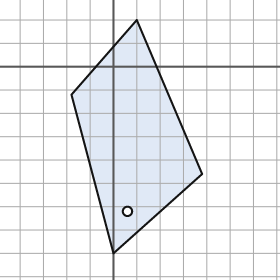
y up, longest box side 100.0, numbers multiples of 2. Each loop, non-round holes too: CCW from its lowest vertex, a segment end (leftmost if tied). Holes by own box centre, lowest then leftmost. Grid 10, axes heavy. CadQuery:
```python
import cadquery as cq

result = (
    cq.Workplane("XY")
    .moveTo(0.0, -80.0)
    .lineTo(38.0, -46.0)
    .lineTo(10.0, 20.0)
    .lineTo(-18.0, -12.0)
    .close()
    .moveTo(6.0, -62.0)
    .circle(2.0)
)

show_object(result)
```